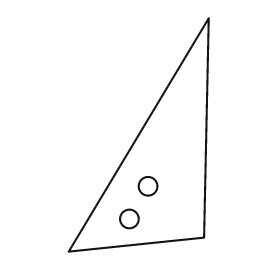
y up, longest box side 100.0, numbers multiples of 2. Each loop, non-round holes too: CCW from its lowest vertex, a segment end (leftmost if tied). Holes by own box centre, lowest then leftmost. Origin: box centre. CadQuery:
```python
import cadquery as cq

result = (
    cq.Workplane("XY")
    .moveTo(-30.0, -50.0)
    .lineTo(28.0, -44.0)
    .lineTo(30.0, 50.0)
    .close()
    .moveTo(-4.0, -36.0)
    .circle(4.0)
    .moveTo(4.0, -22.0)
    .circle(4.0)
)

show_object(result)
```